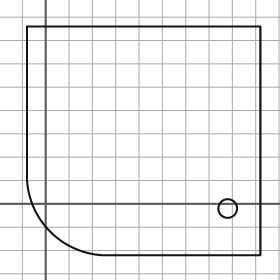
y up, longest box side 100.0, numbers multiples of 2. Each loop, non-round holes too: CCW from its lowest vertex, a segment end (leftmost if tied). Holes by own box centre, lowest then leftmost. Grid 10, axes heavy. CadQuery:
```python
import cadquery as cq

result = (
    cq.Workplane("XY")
    .moveTo(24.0, -22.0)
    .lineTo(92.0, -22.0)
    .lineTo(92.0, 76.0)
    .lineTo(-8.0, 76.0)
    .lineTo(-8.0, 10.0)
    .threePointArc((2.0, -12.0), (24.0, -22.0))
    .close()
    .moveTo(78.0, -2.0)
    .circle(4.0)
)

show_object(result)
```